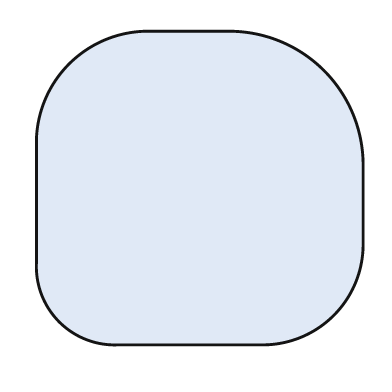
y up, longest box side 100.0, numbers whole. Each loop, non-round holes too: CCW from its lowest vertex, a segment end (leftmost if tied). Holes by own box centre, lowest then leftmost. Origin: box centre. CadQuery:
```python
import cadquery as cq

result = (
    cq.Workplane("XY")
    .moveTo(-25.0, -48.0)
    .lineTo(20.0, -48.0)
    .threePointArc((41.0, -39.0), (50.0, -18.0))
    .lineTo(50.0, 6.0)
    .threePointArc((38.0, 36.0), (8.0, 48.0))
    .lineTo(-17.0, 48.0)
    .threePointArc((-40.0, 38.0), (-50.0, 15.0))
    .lineTo(-50.0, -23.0)
    .threePointArc((-43.0, -41.0), (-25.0, -48.0))
    .close()
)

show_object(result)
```